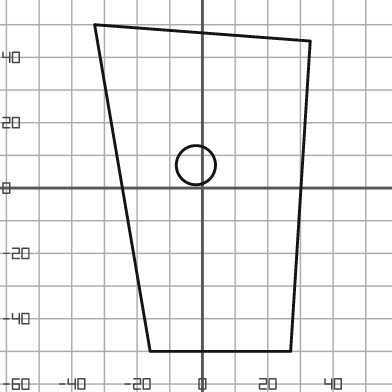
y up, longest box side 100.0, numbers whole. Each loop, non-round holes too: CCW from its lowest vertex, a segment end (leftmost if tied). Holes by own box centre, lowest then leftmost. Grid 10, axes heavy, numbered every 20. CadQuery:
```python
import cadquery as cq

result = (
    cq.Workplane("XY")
    .moveTo(-16.0, -50.0)
    .lineTo(27.0, -50.0)
    .lineTo(33.0, 45.0)
    .lineTo(-33.0, 50.0)
    .close()
    .moveTo(-2.0, 7.0)
    .circle(6.0)
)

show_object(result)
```